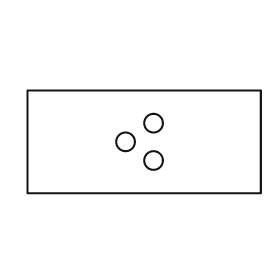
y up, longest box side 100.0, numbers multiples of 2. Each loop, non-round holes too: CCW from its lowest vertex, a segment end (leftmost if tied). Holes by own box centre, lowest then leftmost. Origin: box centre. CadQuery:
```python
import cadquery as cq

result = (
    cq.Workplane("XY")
    .moveTo(-50.0, -22.0)
    .lineTo(50.0, -22.0)
    .lineTo(50.0, 22.0)
    .lineTo(-50.0, 22.0)
    .close()
    .moveTo(4.0, -8.0)
    .circle(4.0)
    .moveTo(-8.0, 0.0)
    .circle(4.0)
    .moveTo(4.0, 8.0)
    .circle(4.0)
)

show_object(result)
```